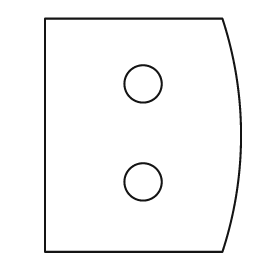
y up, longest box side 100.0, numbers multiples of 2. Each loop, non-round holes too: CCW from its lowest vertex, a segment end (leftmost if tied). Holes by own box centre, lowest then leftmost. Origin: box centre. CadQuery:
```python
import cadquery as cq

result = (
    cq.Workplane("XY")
    .moveTo(-42.0, -50.0)
    .lineTo(34.0, -50.0)
    .threePointArc((42.0, 0.0), (34.0, 50.0))
    .lineTo(-42.0, 50.0)
    .close()
    .moveTo(0.0, -20.0)
    .circle(8.0)
    .moveTo(0.0, 22.0)
    .circle(8.0)
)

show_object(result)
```